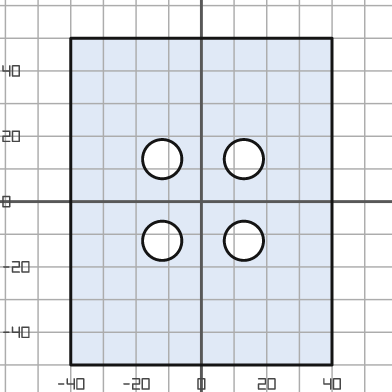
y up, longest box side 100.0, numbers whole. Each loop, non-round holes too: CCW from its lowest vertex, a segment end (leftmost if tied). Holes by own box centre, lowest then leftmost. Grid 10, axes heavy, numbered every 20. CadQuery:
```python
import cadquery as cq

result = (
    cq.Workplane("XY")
    .moveTo(-40.0, -50.0)
    .lineTo(40.0, -50.0)
    .lineTo(40.0, 50.0)
    .lineTo(-40.0, 50.0)
    .close()
    .moveTo(-12.0, -12.0)
    .circle(6.0)
    .moveTo(13.0, -12.0)
    .circle(6.0)
    .moveTo(-12.0, 13.0)
    .circle(6.0)
    .moveTo(13.0, 13.0)
    .circle(6.0)
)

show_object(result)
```